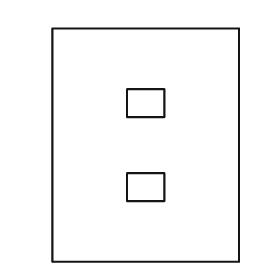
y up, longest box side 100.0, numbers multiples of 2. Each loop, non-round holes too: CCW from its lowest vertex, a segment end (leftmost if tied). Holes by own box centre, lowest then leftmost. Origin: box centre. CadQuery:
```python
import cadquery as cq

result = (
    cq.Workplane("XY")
    .moveTo(-40.0, -50.0)
    .lineTo(40.0, -50.0)
    .lineTo(40.0, 50.0)
    .lineTo(-40.0, 50.0)
    .close()
    .moveTo(-8.0, -24.0)
    .lineTo(8.0, -24.0)
    .lineTo(8.0, -12.0)
    .lineTo(-8.0, -12.0)
    .close()
    .moveTo(-8.0, 12.0)
    .lineTo(8.0, 12.0)
    .lineTo(8.0, 24.0)
    .lineTo(-8.0, 24.0)
    .close()
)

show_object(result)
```